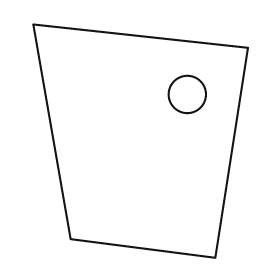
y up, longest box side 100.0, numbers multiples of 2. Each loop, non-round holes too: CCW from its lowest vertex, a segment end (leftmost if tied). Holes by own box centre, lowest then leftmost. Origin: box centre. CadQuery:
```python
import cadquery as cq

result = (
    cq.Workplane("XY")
    .moveTo(32.0, -50.0)
    .lineTo(46.0, 40.0)
    .lineTo(-46.0, 50.0)
    .lineTo(-30.0, -42.0)
    .close()
    .moveTo(20.0, 20.0)
    .circle(8.0)
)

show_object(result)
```